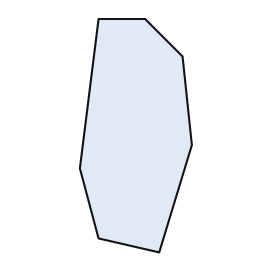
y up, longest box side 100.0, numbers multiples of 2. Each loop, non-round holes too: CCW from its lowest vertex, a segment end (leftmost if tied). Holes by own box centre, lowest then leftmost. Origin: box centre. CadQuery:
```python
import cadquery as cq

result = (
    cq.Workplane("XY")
    .moveTo(10.0, -50.0)
    .lineTo(24.0, -4.0)
    .lineTo(20.0, 34.0)
    .lineTo(4.0, 50.0)
    .lineTo(-16.0, 50.0)
    .lineTo(-24.0, -14.0)
    .lineTo(-16.0, -44.0)
    .close()
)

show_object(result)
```